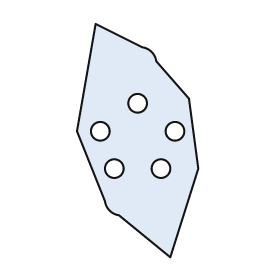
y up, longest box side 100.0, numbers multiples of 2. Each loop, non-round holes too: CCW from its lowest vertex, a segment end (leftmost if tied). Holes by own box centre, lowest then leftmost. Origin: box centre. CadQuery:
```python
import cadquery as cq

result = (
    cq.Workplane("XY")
    .moveTo(14.0, -50.0)
    .lineTo(26.0, -12.0)
    .lineTo(22.0, 18.0)
    .lineTo(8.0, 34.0)
    .threePointArc((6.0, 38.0), (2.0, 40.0))
    .lineTo(-18.0, 50.0)
    .lineTo(-26.0, 4.0)
    .lineTo(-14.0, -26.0)
    .threePointArc((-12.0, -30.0), (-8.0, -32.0))
    .close()
    .moveTo(-10.0, -12.0)
    .circle(4.0)
    .moveTo(10.0, -12.0)
    .circle(4.0)
    .moveTo(-16.0, 4.0)
    .circle(4.0)
    .moveTo(16.0, 4.0)
    .circle(4.0)
    .moveTo(0.0, 16.0)
    .circle(4.0)
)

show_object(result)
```